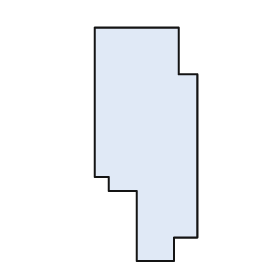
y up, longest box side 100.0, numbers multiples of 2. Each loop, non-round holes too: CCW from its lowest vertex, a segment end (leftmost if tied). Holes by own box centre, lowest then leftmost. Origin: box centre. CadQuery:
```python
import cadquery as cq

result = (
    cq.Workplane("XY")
    .moveTo(-4.0, -50.0)
    .lineTo(12.0, -50.0)
    .lineTo(12.0, -40.0)
    .lineTo(22.0, -40.0)
    .lineTo(22.0, 30.0)
    .lineTo(14.0, 30.0)
    .lineTo(14.0, 50.0)
    .lineTo(-22.0, 50.0)
    .lineTo(-22.0, -14.0)
    .lineTo(-16.0, -14.0)
    .lineTo(-16.0, -20.0)
    .lineTo(-4.0, -20.0)
    .close()
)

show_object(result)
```